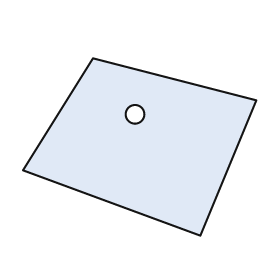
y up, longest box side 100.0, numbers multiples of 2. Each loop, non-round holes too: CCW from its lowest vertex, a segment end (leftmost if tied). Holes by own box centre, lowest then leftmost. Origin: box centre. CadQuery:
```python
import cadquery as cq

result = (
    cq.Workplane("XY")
    .moveTo(26.0, -38.0)
    .lineTo(50.0, 20.0)
    .lineTo(-20.0, 38.0)
    .lineTo(-50.0, -10.0)
    .close()
    .moveTo(-2.0, 14.0)
    .circle(4.0)
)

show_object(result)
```